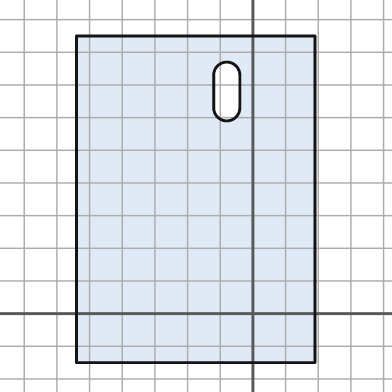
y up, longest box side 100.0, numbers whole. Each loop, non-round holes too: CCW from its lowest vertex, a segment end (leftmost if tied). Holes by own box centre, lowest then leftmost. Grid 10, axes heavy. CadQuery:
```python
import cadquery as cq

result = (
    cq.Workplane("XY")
    .moveTo(-54.0, -15.0)
    .lineTo(19.0, -15.0)
    .lineTo(19.0, 85.0)
    .lineTo(-54.0, 85.0)
    .close()
    .moveTo(-12.0, 63.0)
    .threePointArc((-8.0, 59.0), (-4.0, 63.0))
    .lineTo(-4.0, 73.0)
    .threePointArc((-8.0, 77.0), (-12.0, 73.0))
    .close()
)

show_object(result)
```